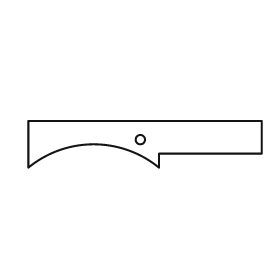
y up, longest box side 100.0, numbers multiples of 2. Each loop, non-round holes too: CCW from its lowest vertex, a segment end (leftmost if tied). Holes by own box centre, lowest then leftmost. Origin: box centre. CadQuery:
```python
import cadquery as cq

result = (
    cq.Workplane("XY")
    .moveTo(-50.0, -10.0)
    .threePointArc((-22.0, 0.0), (6.0, -10.0))
    .lineTo(6.0, -4.0)
    .lineTo(50.0, -4.0)
    .lineTo(50.0, 10.0)
    .lineTo(-50.0, 10.0)
    .close()
    .moveTo(-2.0, 2.0)
    .circle(2.0)
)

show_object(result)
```